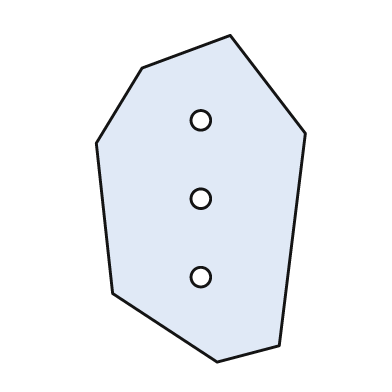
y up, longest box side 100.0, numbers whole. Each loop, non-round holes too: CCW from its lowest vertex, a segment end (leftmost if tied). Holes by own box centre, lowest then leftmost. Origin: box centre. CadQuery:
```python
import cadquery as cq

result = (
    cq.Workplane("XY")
    .moveTo(5.0, -50.0)
    .lineTo(24.0, -45.0)
    .lineTo(32.0, 20.0)
    .lineTo(9.0, 50.0)
    .lineTo(-18.0, 40.0)
    .lineTo(-32.0, 17.0)
    .lineTo(-27.0, -29.0)
    .close()
    .moveTo(0.0, -24.0)
    .circle(3.0)
    .moveTo(0.0, 0.0)
    .circle(3.0)
    .moveTo(0.0, 24.0)
    .circle(3.0)
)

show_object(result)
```